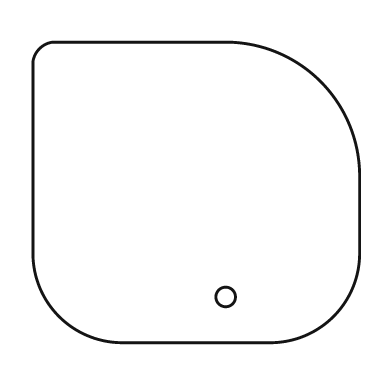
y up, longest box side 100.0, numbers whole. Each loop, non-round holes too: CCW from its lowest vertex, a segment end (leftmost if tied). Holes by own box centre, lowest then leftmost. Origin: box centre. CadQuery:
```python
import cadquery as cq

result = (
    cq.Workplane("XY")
    .moveTo(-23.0, -46.0)
    .lineTo(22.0, -46.0)
    .threePointArc((42.0, -38.0), (50.0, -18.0))
    .lineTo(50.0, 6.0)
    .threePointArc((38.0, 34.0), (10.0, 46.0))
    .lineTo(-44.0, 46.0)
    .threePointArc((-48.0, 44.0), (-50.0, 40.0))
    .lineTo(-50.0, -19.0)
    .threePointArc((-42.0, -38.0), (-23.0, -46.0))
    .close()
    .moveTo(9.0, -32.0)
    .circle(3.0)
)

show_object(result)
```